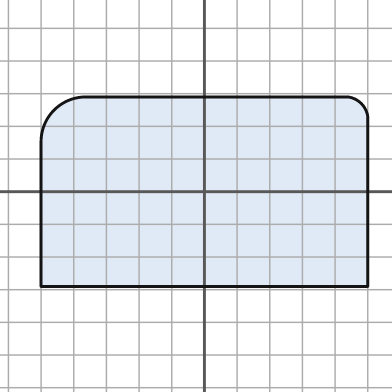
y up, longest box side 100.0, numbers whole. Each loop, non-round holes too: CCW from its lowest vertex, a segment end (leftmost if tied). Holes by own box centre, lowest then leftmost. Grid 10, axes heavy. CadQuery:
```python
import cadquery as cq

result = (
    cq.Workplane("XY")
    .moveTo(-50.0, -29.0)
    .lineTo(50.0, -29.0)
    .lineTo(50.0, 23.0)
    .threePointArc((48.0, 27.0), (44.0, 29.0))
    .lineTo(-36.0, 29.0)
    .threePointArc((-46.0, 25.0), (-50.0, 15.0))
    .close()
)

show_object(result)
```